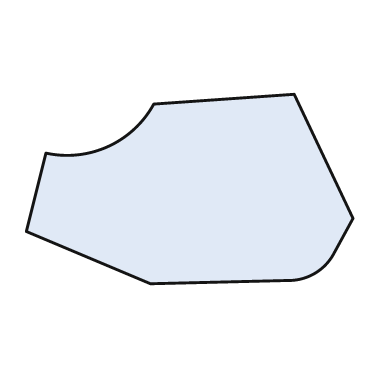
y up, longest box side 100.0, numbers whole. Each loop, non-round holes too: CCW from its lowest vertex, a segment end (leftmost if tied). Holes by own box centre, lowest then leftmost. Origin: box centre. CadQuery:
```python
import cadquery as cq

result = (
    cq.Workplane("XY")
    .moveTo(-12.0, -29.0)
    .lineTo(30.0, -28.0)
    .threePointArc((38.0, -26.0), (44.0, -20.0))
    .lineTo(50.0, -9.0)
    .lineTo(32.0, 29.0)
    .lineTo(-11.0, 26.0)
    .threePointArc((-25.0, 13.0), (-44.0, 11.0))
    .lineTo(-50.0, -13.0)
    .close()
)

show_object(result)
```